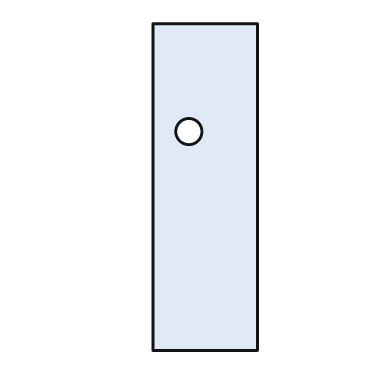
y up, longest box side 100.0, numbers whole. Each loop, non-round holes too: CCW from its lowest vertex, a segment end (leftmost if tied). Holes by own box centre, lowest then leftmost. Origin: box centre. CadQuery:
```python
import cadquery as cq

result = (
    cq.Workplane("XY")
    .moveTo(-16.0, -50.0)
    .lineTo(16.0, -50.0)
    .lineTo(16.0, 50.0)
    .lineTo(-16.0, 50.0)
    .close()
    .moveTo(-5.0, 17.0)
    .circle(4.0)
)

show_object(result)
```